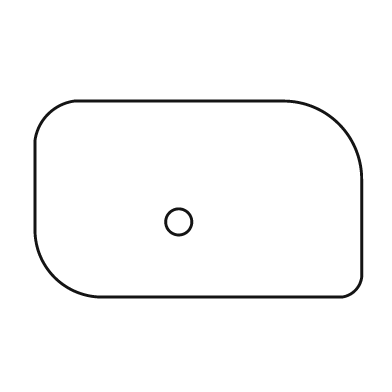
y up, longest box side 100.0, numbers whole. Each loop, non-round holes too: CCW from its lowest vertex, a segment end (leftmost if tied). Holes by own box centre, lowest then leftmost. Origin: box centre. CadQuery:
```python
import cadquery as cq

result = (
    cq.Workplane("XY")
    .moveTo(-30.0, -30.0)
    .lineTo(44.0, -30.0)
    .threePointArc((48.0, -28.0), (50.0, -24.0))
    .lineTo(50.0, 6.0)
    .threePointArc((43.0, 23.0), (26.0, 30.0))
    .lineTo(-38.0, 30.0)
    .threePointArc((-46.0, 26.0), (-50.0, 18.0))
    .lineTo(-50.0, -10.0)
    .threePointArc((-44.0, -24.0), (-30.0, -30.0))
    .close()
    .moveTo(-6.0, -7.0)
    .circle(4.0)
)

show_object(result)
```